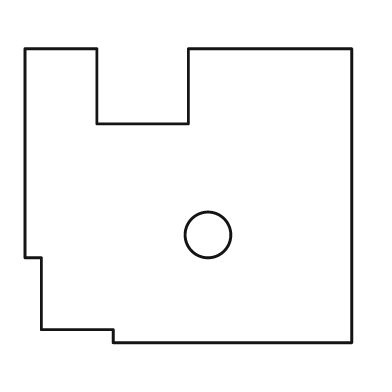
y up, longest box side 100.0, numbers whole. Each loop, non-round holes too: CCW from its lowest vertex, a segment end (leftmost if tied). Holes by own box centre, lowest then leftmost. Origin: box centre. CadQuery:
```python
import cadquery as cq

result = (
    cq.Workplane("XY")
    .moveTo(-23.0, -45.0)
    .lineTo(50.0, -45.0)
    .lineTo(50.0, 45.0)
    .lineTo(0.0, 45.0)
    .lineTo(0.0, 22.0)
    .lineTo(-28.0, 22.0)
    .lineTo(-28.0, 45.0)
    .lineTo(-50.0, 45.0)
    .lineTo(-50.0, -19.0)
    .lineTo(-45.0, -19.0)
    .lineTo(-45.0, -41.0)
    .lineTo(-23.0, -41.0)
    .close()
    .moveTo(6.0, -12.0)
    .circle(7.0)
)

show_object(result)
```